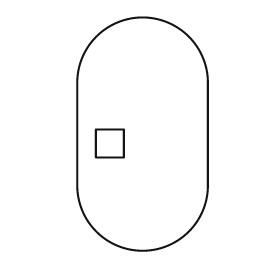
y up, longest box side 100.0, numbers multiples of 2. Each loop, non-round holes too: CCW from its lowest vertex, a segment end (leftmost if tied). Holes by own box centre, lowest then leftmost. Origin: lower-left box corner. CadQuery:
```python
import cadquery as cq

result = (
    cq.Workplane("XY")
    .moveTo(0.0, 28.0)
    .threePointArc((28.0, 0.0), (56.0, 28.0))
    .lineTo(56.0, 72.0)
    .threePointArc((28.0, 100.0), (0.0, 72.0))
    .close()
    .moveTo(8.0, 40.0)
    .lineTo(20.0, 40.0)
    .lineTo(20.0, 52.0)
    .lineTo(8.0, 52.0)
    .close()
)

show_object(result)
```